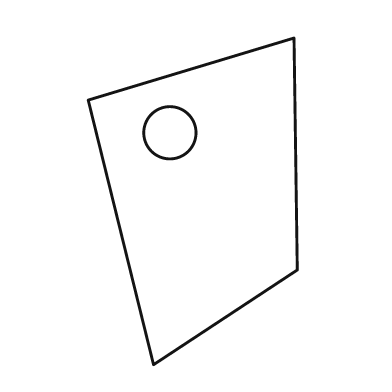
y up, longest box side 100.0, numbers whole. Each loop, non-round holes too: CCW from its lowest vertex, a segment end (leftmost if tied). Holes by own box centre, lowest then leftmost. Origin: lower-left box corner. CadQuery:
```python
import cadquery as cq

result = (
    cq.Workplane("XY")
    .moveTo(20.0, 0.0)
    .lineTo(64.0, 29.0)
    .lineTo(63.0, 100.0)
    .lineTo(0.0, 81.0)
    .close()
    .moveTo(25.0, 71.0)
    .circle(8.0)
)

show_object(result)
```